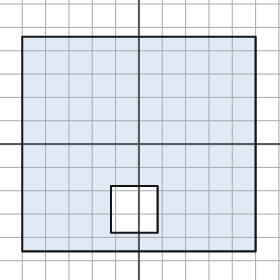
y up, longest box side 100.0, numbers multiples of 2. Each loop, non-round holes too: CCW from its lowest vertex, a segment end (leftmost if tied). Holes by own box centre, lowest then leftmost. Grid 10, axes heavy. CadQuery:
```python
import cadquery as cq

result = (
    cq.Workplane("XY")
    .moveTo(-50.0, -46.0)
    .lineTo(50.0, -46.0)
    .lineTo(50.0, 46.0)
    .lineTo(-50.0, 46.0)
    .close()
    .moveTo(-12.0, -38.0)
    .lineTo(8.0, -38.0)
    .lineTo(8.0, -18.0)
    .lineTo(-12.0, -18.0)
    .close()
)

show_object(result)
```